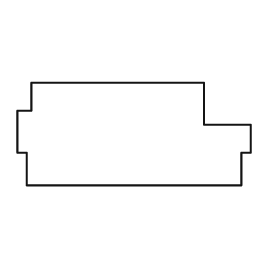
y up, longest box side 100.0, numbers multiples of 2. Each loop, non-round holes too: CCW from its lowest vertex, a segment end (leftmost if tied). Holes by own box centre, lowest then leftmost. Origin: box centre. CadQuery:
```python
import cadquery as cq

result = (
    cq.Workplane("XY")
    .moveTo(-46.0, -22.0)
    .lineTo(46.0, -22.0)
    .lineTo(46.0, -8.0)
    .lineTo(50.0, -8.0)
    .lineTo(50.0, 4.0)
    .lineTo(30.0, 4.0)
    .lineTo(30.0, 22.0)
    .lineTo(-44.0, 22.0)
    .lineTo(-44.0, 10.0)
    .lineTo(-50.0, 10.0)
    .lineTo(-50.0, -8.0)
    .lineTo(-46.0, -8.0)
    .close()
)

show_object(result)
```